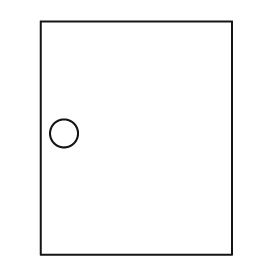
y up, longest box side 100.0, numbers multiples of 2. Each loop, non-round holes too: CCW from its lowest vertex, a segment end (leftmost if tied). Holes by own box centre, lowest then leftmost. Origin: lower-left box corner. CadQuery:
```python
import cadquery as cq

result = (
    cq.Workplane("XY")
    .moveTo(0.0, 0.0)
    .lineTo(82.0, 0.0)
    .lineTo(82.0, 100.0)
    .lineTo(0.0, 100.0)
    .close()
    .moveTo(10.0, 52.0)
    .circle(6.0)
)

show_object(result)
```